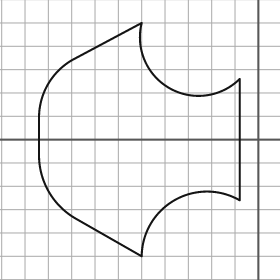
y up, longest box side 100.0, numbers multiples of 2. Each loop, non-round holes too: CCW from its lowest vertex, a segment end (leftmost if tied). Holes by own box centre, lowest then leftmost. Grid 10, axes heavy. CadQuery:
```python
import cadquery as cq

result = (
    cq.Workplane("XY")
    .moveTo(-50.0, -50.0)
    .threePointArc((-36.0, -26.0), (-8.0, -26.0))
    .lineTo(-8.0, 26.0)
    .threePointArc((-38.0, 22.0), (-50.0, 50.0))
    .lineTo(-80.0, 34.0)
    .threePointArc((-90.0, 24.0), (-94.0, 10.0))
    .lineTo(-94.0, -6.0)
    .threePointArc((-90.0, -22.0), (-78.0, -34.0))
    .close()
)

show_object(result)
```